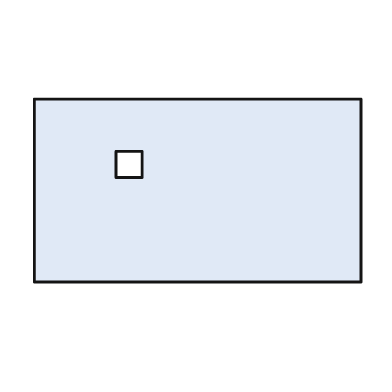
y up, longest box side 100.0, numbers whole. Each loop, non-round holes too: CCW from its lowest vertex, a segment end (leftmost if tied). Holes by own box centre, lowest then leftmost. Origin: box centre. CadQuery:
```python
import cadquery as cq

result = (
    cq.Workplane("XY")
    .moveTo(-50.0, -28.0)
    .lineTo(50.0, -28.0)
    .lineTo(50.0, 28.0)
    .lineTo(-50.0, 28.0)
    .close()
    .moveTo(-25.0, 4.0)
    .lineTo(-17.0, 4.0)
    .lineTo(-17.0, 12.0)
    .lineTo(-25.0, 12.0)
    .close()
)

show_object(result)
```